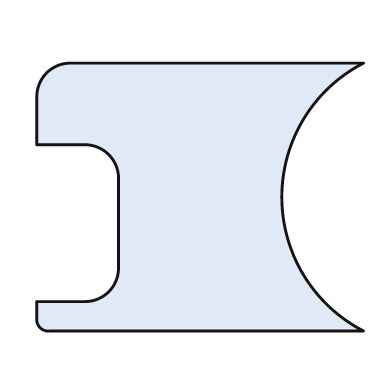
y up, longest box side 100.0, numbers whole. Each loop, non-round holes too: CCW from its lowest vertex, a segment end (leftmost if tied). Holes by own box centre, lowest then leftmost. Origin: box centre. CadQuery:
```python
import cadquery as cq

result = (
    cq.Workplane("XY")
    .moveTo(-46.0, -41.0)
    .lineTo(50.0, -41.0)
    .threePointArc((25.0, 0.0), (50.0, 41.0))
    .lineTo(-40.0, 41.0)
    .threePointArc((-47.0, 38.0), (-50.0, 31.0))
    .lineTo(-50.0, 16.0)
    .lineTo(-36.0, 16.0)
    .threePointArc((-28.0, 13.0), (-25.0, 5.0))
    .lineTo(-25.0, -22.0)
    .threePointArc((-28.0, -29.0), (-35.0, -32.0))
    .lineTo(-50.0, -32.0)
    .lineTo(-50.0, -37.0)
    .threePointArc((-49.0, -40.0), (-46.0, -41.0))
    .close()
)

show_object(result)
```